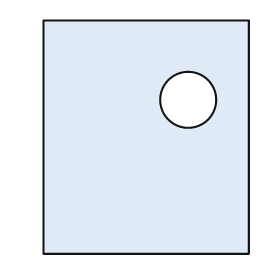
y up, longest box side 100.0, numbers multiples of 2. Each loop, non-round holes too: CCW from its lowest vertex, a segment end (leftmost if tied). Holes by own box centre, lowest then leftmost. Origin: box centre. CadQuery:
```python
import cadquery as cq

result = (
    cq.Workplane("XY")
    .moveTo(-44.0, -50.0)
    .lineTo(44.0, -50.0)
    .lineTo(44.0, 50.0)
    .lineTo(-44.0, 50.0)
    .close()
    .moveTo(18.0, 16.0)
    .circle(12.0)
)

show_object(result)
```